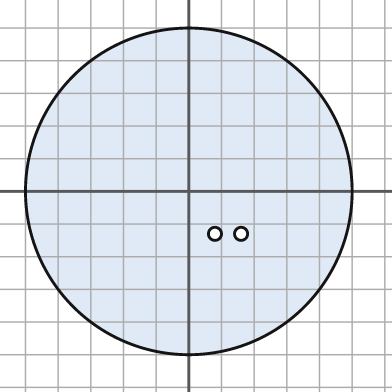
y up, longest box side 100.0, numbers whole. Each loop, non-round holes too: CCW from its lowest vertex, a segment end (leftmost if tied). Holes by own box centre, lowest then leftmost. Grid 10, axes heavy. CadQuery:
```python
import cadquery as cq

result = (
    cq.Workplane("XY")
    .moveTo(0.0, 0.0)
    .circle(50.0)
    .moveTo(8.0, -13.0)
    .circle(2.0)
    .moveTo(16.0, -13.0)
    .circle(2.0)
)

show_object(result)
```